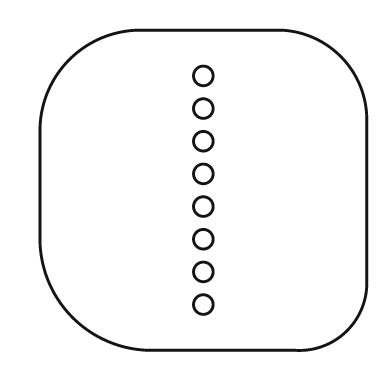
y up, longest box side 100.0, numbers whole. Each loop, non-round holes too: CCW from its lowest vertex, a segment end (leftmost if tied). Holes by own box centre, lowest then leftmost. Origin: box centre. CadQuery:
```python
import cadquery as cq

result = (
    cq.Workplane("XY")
    .moveTo(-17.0, -49.0)
    .lineTo(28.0, -49.0)
    .threePointArc((44.0, -43.0), (50.0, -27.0))
    .lineTo(50.0, 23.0)
    .threePointArc((42.0, 41.0), (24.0, 49.0))
    .lineTo(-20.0, 49.0)
    .threePointArc((-41.0, 40.0), (-50.0, 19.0))
    .lineTo(-50.0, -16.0)
    .threePointArc((-40.0, -39.0), (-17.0, -49.0))
    .close()
    .moveTo(0.0, -35.0)
    .circle(3.0)
    .moveTo(0.0, -25.0)
    .circle(3.0)
    .moveTo(0.0, -15.0)
    .circle(3.0)
    .moveTo(0.0, -5.0)
    .circle(3.0)
    .moveTo(0.0, 5.0)
    .circle(3.0)
    .moveTo(0.0, 15.0)
    .circle(3.0)
    .moveTo(0.0, 25.0)
    .circle(3.0)
    .moveTo(0.0, 35.0)
    .circle(3.0)
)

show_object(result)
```